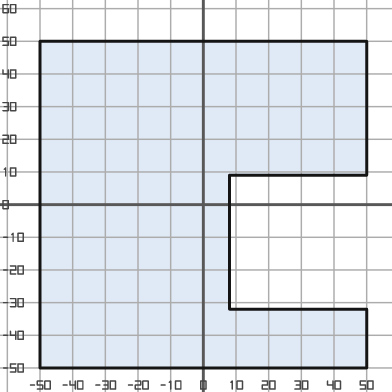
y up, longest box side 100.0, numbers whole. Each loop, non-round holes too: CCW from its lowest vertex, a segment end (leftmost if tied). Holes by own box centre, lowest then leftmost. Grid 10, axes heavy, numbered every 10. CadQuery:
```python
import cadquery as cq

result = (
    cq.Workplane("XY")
    .moveTo(-50.0, -50.0)
    .lineTo(50.0, -50.0)
    .lineTo(50.0, -32.0)
    .lineTo(8.0, -32.0)
    .lineTo(8.0, 9.0)
    .lineTo(50.0, 9.0)
    .lineTo(50.0, 50.0)
    .lineTo(-50.0, 50.0)
    .close()
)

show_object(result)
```